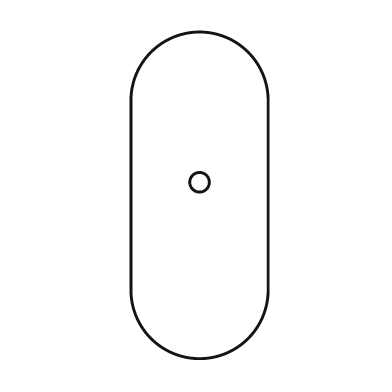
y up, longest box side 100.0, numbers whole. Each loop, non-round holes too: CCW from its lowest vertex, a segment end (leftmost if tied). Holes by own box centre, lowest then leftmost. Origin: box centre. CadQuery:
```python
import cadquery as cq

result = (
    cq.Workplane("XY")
    .moveTo(-21.0, -29.0)
    .threePointArc((0.0, -50.0), (21.0, -29.0))
    .lineTo(21.0, 29.0)
    .threePointArc((0.0, 50.0), (-21.0, 29.0))
    .close()
    .moveTo(0.0, 4.0)
    .circle(3.0)
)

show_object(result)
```